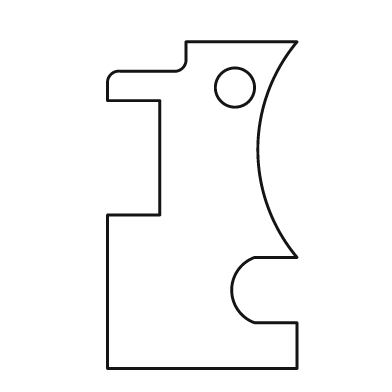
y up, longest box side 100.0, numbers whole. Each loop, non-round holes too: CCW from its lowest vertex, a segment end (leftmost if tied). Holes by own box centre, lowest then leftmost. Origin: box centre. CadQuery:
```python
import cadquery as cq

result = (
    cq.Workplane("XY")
    .moveTo(-29.0, -50.0)
    .lineTo(29.0, -50.0)
    .lineTo(29.0, -36.0)
    .lineTo(16.0, -36.0)
    .threePointArc((9.0, -26.0), (16.0, -16.0))
    .lineTo(29.0, -16.0)
    .threePointArc((17.0, 17.0), (29.0, 50.0))
    .lineTo(-5.0, 50.0)
    .lineTo(-5.0, 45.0)
    .threePointArc((-6.0, 42.0), (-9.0, 41.0))
    .lineTo(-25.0, 41.0)
    .threePointArc((-28.0, 40.0), (-29.0, 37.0))
    .lineTo(-29.0, 32.0)
    .lineTo(-13.0, 32.0)
    .lineTo(-13.0, -3.0)
    .lineTo(-29.0, -3.0)
    .close()
    .moveTo(10.0, 36.0)
    .circle(6.0)
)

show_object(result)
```